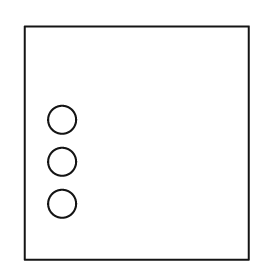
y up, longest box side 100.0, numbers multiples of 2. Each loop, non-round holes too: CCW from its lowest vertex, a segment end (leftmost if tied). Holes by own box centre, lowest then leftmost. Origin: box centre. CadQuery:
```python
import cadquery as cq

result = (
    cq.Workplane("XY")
    .moveTo(-48.0, -50.0)
    .lineTo(48.0, -50.0)
    .lineTo(48.0, 50.0)
    .lineTo(-48.0, 50.0)
    .close()
    .moveTo(-32.0, -26.0)
    .circle(6.0)
    .moveTo(-32.0, -8.0)
    .circle(6.0)
    .moveTo(-32.0, 10.0)
    .circle(6.0)
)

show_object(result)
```